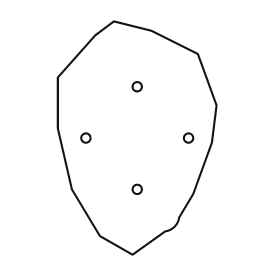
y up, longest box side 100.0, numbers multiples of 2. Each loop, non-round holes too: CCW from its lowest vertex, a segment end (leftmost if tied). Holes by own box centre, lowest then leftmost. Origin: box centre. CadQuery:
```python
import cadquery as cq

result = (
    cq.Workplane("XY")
    .moveTo(-2.0, -50.0)
    .lineTo(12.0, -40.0)
    .threePointArc((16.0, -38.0), (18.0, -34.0))
    .lineTo(24.0, -24.0)
    .lineTo(32.0, -2.0)
    .lineTo(34.0, 14.0)
    .lineTo(26.0, 36.0)
    .lineTo(6.0, 46.0)
    .lineTo(-10.0, 50.0)
    .lineTo(-18.0, 44.0)
    .lineTo(-34.0, 26.0)
    .lineTo(-34.0, 4.0)
    .lineTo(-28.0, -22.0)
    .lineTo(-16.0, -42.0)
    .close()
    .moveTo(0.0, -22.0)
    .circle(2.0)
    .moveTo(-22.0, 0.0)
    .circle(2.0)
    .moveTo(22.0, 0.0)
    .circle(2.0)
    .moveTo(0.0, 22.0)
    .circle(2.0)
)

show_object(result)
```